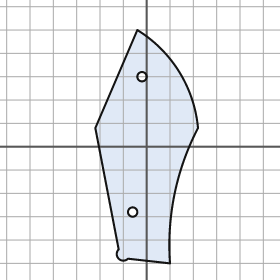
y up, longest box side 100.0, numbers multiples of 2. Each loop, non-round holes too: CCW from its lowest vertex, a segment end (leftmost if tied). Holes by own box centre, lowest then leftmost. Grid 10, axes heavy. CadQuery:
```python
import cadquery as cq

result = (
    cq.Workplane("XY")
    .moveTo(10.0, -50.0)
    .threePointArc((12.0, -20.0), (22.0, 8.0))
    .threePointArc((14.0, 32.0), (-4.0, 50.0))
    .lineTo(-22.0, 8.0)
    .lineTo(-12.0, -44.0)
    .threePointArc((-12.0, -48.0), (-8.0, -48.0))
    .close()
    .moveTo(-6.0, -28.0)
    .circle(2.0)
    .moveTo(-2.0, 30.0)
    .circle(2.0)
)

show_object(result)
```